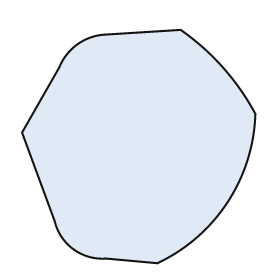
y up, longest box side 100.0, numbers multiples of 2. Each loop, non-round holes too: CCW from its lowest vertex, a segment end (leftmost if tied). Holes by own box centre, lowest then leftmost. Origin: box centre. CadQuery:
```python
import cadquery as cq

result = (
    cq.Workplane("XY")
    .moveTo(8.0, -50.0)
    .threePointArc((38.0, -24.0), (50.0, 14.0))
    .threePointArc((36.0, 34.0), (18.0, 50.0))
    .lineTo(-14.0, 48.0)
    .threePointArc((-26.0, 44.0), (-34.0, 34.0))
    .lineTo(-50.0, 6.0)
    .lineTo(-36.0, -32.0)
    .threePointArc((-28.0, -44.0), (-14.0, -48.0))
    .close()
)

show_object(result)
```